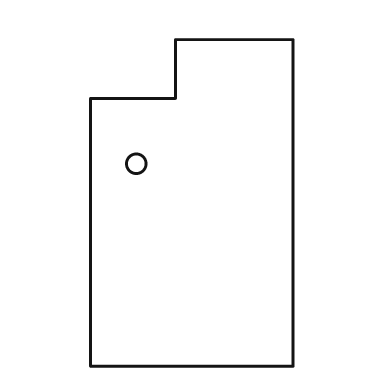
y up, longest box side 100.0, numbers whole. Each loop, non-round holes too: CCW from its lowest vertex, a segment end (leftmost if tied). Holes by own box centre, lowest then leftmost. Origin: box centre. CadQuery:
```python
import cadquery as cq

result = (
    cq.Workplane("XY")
    .moveTo(-31.0, -50.0)
    .lineTo(31.0, -50.0)
    .lineTo(31.0, 50.0)
    .lineTo(-5.0, 50.0)
    .lineTo(-5.0, 32.0)
    .lineTo(-31.0, 32.0)
    .close()
    .moveTo(-17.0, 12.0)
    .circle(3.0)
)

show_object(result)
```